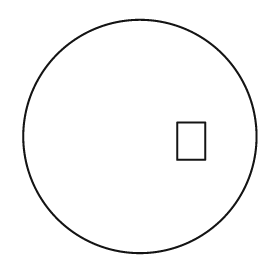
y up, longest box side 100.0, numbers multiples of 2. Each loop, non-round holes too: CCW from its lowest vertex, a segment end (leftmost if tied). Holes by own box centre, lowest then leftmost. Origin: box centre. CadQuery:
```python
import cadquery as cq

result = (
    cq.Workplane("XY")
    .moveTo(0.0, 0.0)
    .circle(50.0)
    .moveTo(16.0, -10.0)
    .lineTo(28.0, -10.0)
    .lineTo(28.0, 6.0)
    .lineTo(16.0, 6.0)
    .close()
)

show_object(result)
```